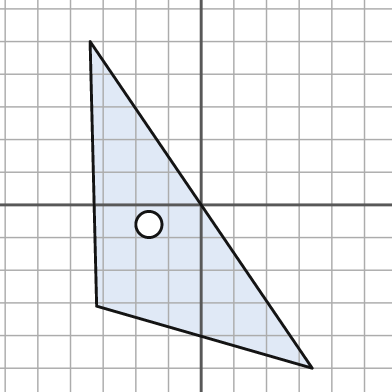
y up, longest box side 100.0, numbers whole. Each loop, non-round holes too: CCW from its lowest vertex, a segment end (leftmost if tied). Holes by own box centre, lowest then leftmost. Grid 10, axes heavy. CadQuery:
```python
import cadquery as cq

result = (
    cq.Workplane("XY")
    .moveTo(34.0, -50.0)
    .lineTo(-34.0, 50.0)
    .lineTo(-32.0, -31.0)
    .close()
    .moveTo(-16.0, -6.0)
    .circle(4.0)
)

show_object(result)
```